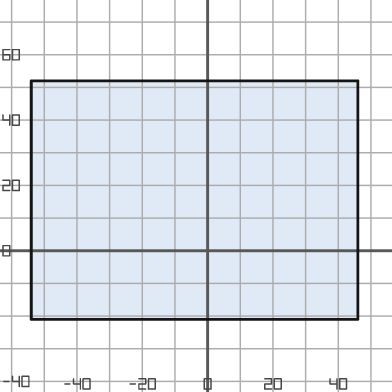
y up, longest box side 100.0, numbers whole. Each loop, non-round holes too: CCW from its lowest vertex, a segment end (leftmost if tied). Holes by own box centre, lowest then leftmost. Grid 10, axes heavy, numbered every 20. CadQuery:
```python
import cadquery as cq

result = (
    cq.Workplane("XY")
    .moveTo(-54.0, -21.0)
    .lineTo(46.0, -21.0)
    .lineTo(46.0, 52.0)
    .lineTo(-54.0, 52.0)
    .close()
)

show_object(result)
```